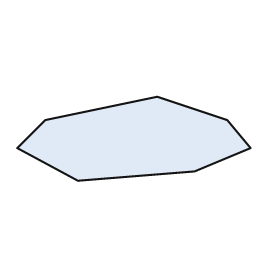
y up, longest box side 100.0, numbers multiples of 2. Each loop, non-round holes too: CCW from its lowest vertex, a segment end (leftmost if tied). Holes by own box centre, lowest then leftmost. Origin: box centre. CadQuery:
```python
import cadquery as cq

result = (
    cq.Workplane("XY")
    .moveTo(-24.0, -18.0)
    .lineTo(26.0, -14.0)
    .lineTo(50.0, -4.0)
    .lineTo(40.0, 8.0)
    .lineTo(10.0, 18.0)
    .lineTo(-38.0, 8.0)
    .lineTo(-50.0, -4.0)
    .close()
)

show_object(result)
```